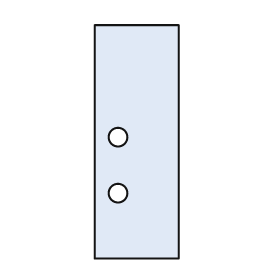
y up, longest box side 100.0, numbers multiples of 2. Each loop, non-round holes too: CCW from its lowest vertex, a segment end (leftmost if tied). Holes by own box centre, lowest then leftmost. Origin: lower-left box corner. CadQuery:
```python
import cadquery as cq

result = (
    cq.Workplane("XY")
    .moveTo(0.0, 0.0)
    .lineTo(36.0, 0.0)
    .lineTo(36.0, 100.0)
    .lineTo(0.0, 100.0)
    .close()
    .moveTo(10.0, 28.0)
    .circle(4.0)
    .moveTo(10.0, 52.0)
    .circle(4.0)
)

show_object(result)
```